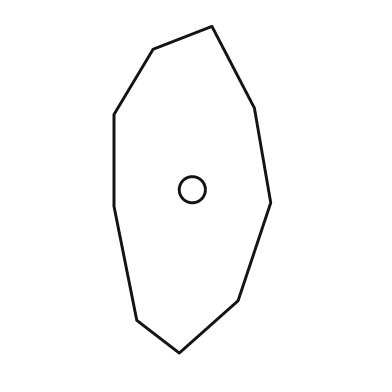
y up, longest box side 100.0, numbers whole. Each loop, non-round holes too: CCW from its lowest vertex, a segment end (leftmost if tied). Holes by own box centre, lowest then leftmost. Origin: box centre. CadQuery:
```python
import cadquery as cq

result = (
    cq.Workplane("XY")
    .moveTo(-4.0, -50.0)
    .lineTo(14.0, -34.0)
    .lineTo(24.0, -4.0)
    .lineTo(19.0, 25.0)
    .lineTo(6.0, 50.0)
    .lineTo(-12.0, 43.0)
    .lineTo(-24.0, 23.0)
    .lineTo(-24.0, -5.0)
    .lineTo(-17.0, -40.0)
    .close()
    .moveTo(0.0, 0.0)
    .circle(4.0)
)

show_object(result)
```